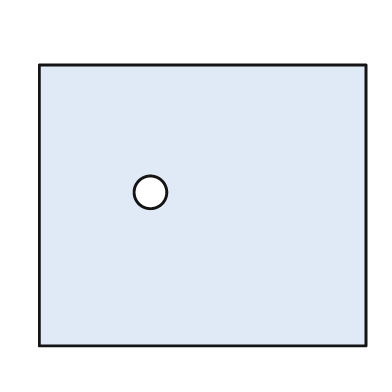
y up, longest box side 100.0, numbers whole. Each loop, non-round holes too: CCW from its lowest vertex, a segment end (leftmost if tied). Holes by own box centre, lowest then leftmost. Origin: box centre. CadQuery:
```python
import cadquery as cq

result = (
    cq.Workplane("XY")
    .moveTo(-50.0, -43.0)
    .lineTo(50.0, -43.0)
    .lineTo(50.0, 43.0)
    .lineTo(-50.0, 43.0)
    .close()
    .moveTo(-16.0, 4.0)
    .circle(5.0)
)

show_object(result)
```